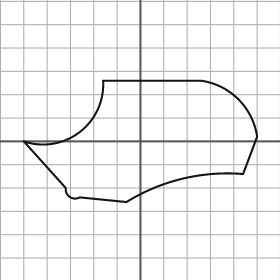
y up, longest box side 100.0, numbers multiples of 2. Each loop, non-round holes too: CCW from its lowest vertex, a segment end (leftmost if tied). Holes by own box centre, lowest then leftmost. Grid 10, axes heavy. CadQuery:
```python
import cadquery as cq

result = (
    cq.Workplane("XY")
    .moveTo(-6.0, -26.0)
    .threePointArc((18.0, -16.0), (44.0, -14.0))
    .lineTo(50.0, 2.0)
    .threePointArc((42.0, 18.0), (26.0, 26.0))
    .lineTo(-16.0, 26.0)
    .threePointArc((-26.0, 4.0), (-50.0, 0.0))
    .lineTo(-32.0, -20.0)
    .threePointArc((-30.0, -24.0), (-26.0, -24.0))
    .close()
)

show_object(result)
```